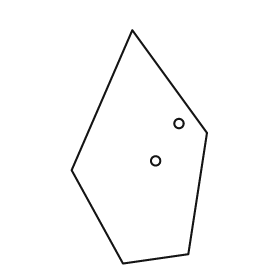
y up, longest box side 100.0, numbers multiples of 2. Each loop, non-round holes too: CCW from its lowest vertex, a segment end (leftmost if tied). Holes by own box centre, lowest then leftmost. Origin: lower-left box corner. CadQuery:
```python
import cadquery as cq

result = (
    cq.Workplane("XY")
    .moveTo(22.0, 0.0)
    .lineTo(50.0, 4.0)
    .lineTo(58.0, 56.0)
    .lineTo(26.0, 100.0)
    .lineTo(0.0, 40.0)
    .close()
    .moveTo(36.0, 44.0)
    .circle(2.0)
    .moveTo(46.0, 60.0)
    .circle(2.0)
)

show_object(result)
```